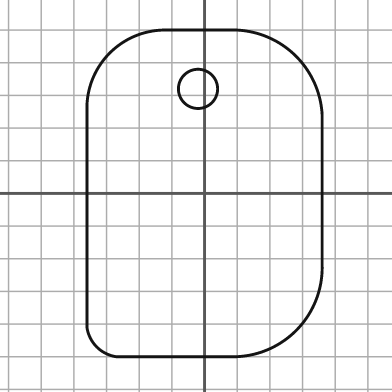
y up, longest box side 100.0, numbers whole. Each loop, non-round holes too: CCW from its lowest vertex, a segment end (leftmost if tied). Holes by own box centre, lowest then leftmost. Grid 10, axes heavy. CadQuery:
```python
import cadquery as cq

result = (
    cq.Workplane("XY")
    .moveTo(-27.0, -50.0)
    .lineTo(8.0, -50.0)
    .threePointArc((28.0, -42.0), (36.0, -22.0))
    .lineTo(36.0, 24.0)
    .threePointArc((28.0, 42.0), (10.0, 50.0))
    .lineTo(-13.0, 50.0)
    .threePointArc((-29.0, 43.0), (-36.0, 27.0))
    .lineTo(-36.0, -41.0)
    .threePointArc((-33.0, -47.0), (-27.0, -50.0))
    .close()
    .moveTo(-2.0, 32.0)
    .circle(6.0)
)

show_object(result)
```